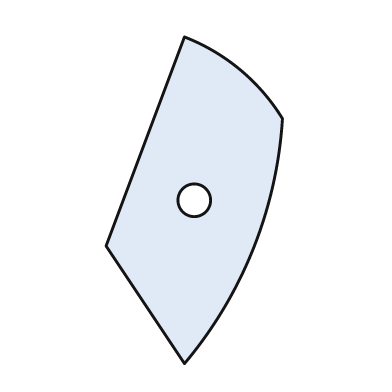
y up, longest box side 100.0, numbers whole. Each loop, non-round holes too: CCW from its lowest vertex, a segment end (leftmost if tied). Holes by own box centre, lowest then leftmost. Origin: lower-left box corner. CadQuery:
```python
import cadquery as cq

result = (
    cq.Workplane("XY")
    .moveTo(24.0, 0.0)
    .threePointArc((45.0, 35.0), (54.0, 75.0))
    .threePointArc((41.0, 90.0), (24.0, 100.0))
    .lineTo(0.0, 36.0)
    .close()
    .moveTo(27.0, 50.0)
    .circle(5.0)
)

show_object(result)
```